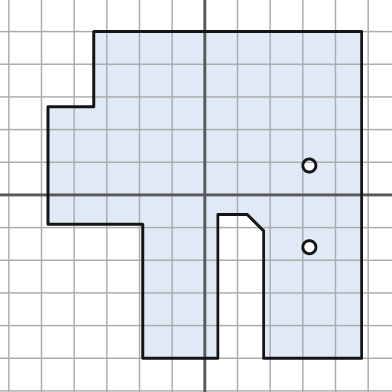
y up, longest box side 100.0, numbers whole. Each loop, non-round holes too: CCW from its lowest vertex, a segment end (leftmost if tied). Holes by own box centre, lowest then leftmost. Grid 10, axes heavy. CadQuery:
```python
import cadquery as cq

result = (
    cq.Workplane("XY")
    .moveTo(-19.0, -50.0)
    .lineTo(4.0, -50.0)
    .lineTo(4.0, -6.0)
    .lineTo(13.0, -6.0)
    .lineTo(18.0, -11.0)
    .lineTo(18.0, -50.0)
    .lineTo(48.0, -50.0)
    .lineTo(48.0, 50.0)
    .lineTo(-34.0, 50.0)
    .lineTo(-34.0, 27.0)
    .lineTo(-48.0, 27.0)
    .lineTo(-48.0, -9.0)
    .lineTo(-19.0, -9.0)
    .close()
    .moveTo(32.0, -16.0)
    .circle(2.0)
    .moveTo(32.0, 9.0)
    .circle(2.0)
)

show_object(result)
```